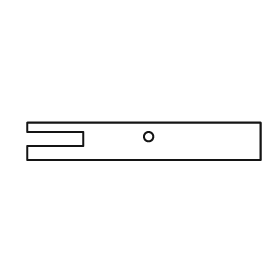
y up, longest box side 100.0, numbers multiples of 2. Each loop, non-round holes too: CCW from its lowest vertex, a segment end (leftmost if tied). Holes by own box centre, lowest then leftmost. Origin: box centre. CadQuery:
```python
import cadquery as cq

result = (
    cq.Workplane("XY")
    .moveTo(-50.0, -8.0)
    .lineTo(50.0, -8.0)
    .lineTo(50.0, 8.0)
    .lineTo(-50.0, 8.0)
    .lineTo(-50.0, 4.0)
    .lineTo(-26.0, 4.0)
    .lineTo(-26.0, -2.0)
    .lineTo(-50.0, -2.0)
    .close()
    .moveTo(2.0, 2.0)
    .circle(2.0)
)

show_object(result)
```